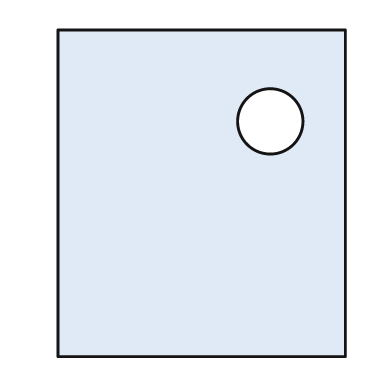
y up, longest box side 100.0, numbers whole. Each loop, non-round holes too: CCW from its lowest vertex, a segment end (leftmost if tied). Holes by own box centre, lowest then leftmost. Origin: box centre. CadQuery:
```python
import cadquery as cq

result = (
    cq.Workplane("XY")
    .moveTo(-44.0, -50.0)
    .lineTo(44.0, -50.0)
    .lineTo(44.0, 50.0)
    .lineTo(-44.0, 50.0)
    .close()
    .moveTo(21.0, 22.0)
    .circle(10.0)
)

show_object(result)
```